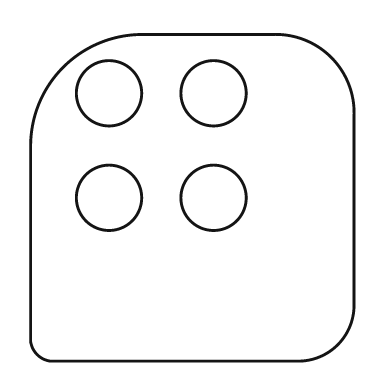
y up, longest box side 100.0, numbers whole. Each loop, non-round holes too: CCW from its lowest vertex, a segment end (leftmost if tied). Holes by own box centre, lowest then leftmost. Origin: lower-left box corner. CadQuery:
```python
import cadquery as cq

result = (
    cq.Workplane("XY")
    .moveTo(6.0, 0.0)
    .lineTo(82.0, 0.0)
    .threePointArc((94.0, 5.0), (99.0, 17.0))
    .lineTo(99.0, 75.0)
    .threePointArc((92.0, 93.0), (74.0, 100.0))
    .lineTo(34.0, 100.0)
    .threePointArc((10.0, 90.0), (0.0, 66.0))
    .lineTo(0.0, 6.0)
    .threePointArc((2.0, 2.0), (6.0, 0.0))
    .close()
    .moveTo(24.0, 50.0)
    .circle(10.0)
    .moveTo(56.0, 50.0)
    .circle(10.0)
    .moveTo(24.0, 82.0)
    .circle(10.0)
    .moveTo(56.0, 82.0)
    .circle(10.0)
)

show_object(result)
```